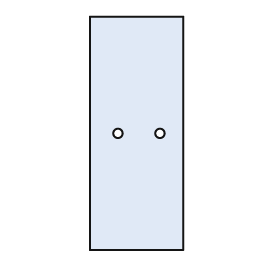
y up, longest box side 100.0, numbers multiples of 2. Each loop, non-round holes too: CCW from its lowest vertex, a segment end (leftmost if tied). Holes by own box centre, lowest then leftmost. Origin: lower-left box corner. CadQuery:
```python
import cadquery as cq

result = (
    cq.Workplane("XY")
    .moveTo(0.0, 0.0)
    .lineTo(40.0, 0.0)
    .lineTo(40.0, 100.0)
    .lineTo(0.0, 100.0)
    .close()
    .moveTo(12.0, 50.0)
    .circle(2.0)
    .moveTo(30.0, 50.0)
    .circle(2.0)
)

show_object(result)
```